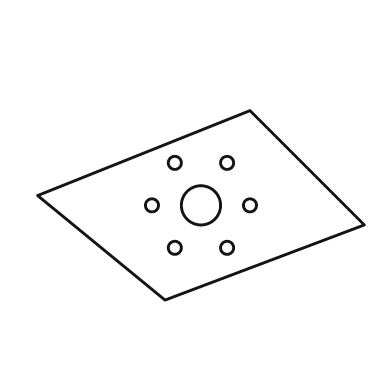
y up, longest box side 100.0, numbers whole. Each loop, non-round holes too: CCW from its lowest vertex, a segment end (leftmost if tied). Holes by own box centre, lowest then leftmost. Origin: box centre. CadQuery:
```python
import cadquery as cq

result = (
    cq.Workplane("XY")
    .moveTo(-11.0, -29.0)
    .lineTo(50.0, -6.0)
    .lineTo(15.0, 29.0)
    .lineTo(-50.0, 3.0)
    .close()
    .moveTo(-8.0, -13.0)
    .circle(2.0)
    .moveTo(8.0, -13.0)
    .circle(2.0)
    .moveTo(-15.0, 0.0)
    .circle(2.0)
    .moveTo(0.0, 0.0)
    .circle(6.0)
    .moveTo(15.0, 0.0)
    .circle(2.0)
    .moveTo(-8.0, 13.0)
    .circle(2.0)
    .moveTo(8.0, 13.0)
    .circle(2.0)
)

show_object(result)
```